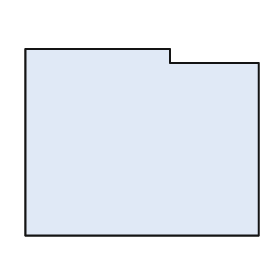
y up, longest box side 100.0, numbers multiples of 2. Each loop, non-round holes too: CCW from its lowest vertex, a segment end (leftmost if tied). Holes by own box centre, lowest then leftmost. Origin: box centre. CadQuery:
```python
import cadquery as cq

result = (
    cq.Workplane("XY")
    .moveTo(-50.0, -40.0)
    .lineTo(50.0, -40.0)
    .lineTo(50.0, 34.0)
    .lineTo(12.0, 34.0)
    .lineTo(12.0, 40.0)
    .lineTo(-50.0, 40.0)
    .close()
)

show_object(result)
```